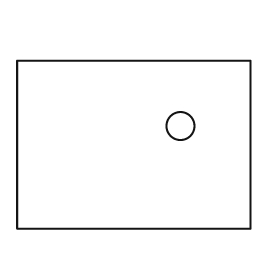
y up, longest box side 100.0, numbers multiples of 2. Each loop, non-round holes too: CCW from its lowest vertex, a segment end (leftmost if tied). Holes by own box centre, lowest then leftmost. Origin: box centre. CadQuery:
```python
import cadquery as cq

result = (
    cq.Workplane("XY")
    .moveTo(-50.0, -36.0)
    .lineTo(50.0, -36.0)
    .lineTo(50.0, 36.0)
    .lineTo(-50.0, 36.0)
    .close()
    .moveTo(20.0, 8.0)
    .circle(6.0)
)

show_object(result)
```